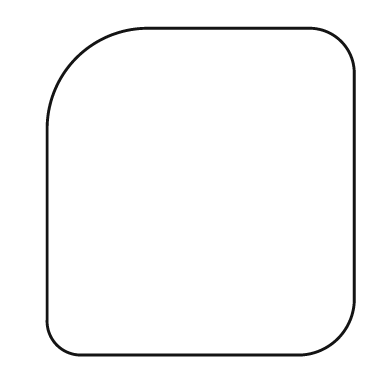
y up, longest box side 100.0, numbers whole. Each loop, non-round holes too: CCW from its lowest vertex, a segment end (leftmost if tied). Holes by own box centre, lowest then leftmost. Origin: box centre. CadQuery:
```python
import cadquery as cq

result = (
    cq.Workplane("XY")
    .moveTo(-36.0, -50.0)
    .lineTo(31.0, -50.0)
    .threePointArc((42.0, -45.0), (47.0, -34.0))
    .lineTo(47.0, 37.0)
    .threePointArc((43.0, 46.0), (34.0, 50.0))
    .lineTo(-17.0, 50.0)
    .threePointArc((-38.0, 41.0), (-47.0, 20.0))
    .lineTo(-47.0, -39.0)
    .threePointArc((-44.0, -47.0), (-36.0, -50.0))
    .close()
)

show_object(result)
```